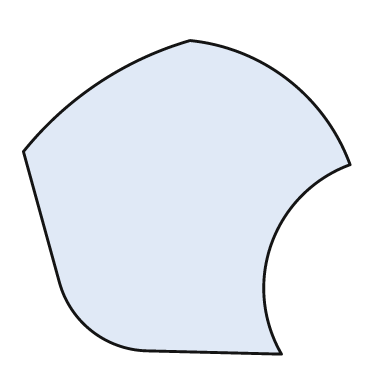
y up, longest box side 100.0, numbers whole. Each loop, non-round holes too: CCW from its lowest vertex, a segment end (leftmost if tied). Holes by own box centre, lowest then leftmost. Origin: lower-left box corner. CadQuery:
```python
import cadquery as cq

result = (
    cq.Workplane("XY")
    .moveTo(79.0, 0.0)
    .threePointArc((76.0, 34.0), (100.0, 58.0))
    .threePointArc((81.0, 84.0), (51.0, 96.0))
    .threePointArc((23.0, 83.0), (0.0, 62.0))
    .lineTo(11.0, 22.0)
    .threePointArc((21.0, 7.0), (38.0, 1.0))
    .close()
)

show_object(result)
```